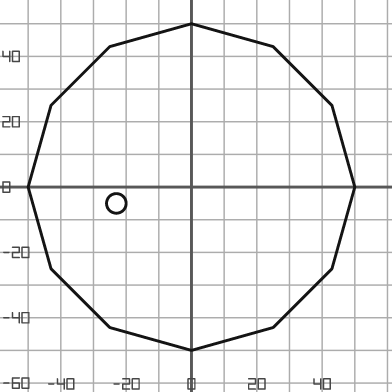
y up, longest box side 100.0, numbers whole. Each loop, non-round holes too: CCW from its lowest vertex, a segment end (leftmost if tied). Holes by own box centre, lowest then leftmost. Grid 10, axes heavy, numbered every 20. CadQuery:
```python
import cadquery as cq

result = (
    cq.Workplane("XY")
    .moveTo(0.0, -50.0)
    .lineTo(25.0, -43.0)
    .lineTo(43.0, -25.0)
    .lineTo(50.0, 0.0)
    .lineTo(43.0, 25.0)
    .lineTo(25.0, 43.0)
    .lineTo(0.0, 50.0)
    .lineTo(-25.0, 43.0)
    .lineTo(-43.0, 25.0)
    .lineTo(-50.0, 0.0)
    .lineTo(-43.0, -25.0)
    .lineTo(-25.0, -43.0)
    .close()
    .moveTo(-23.0, -5.0)
    .circle(3.0)
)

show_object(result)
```